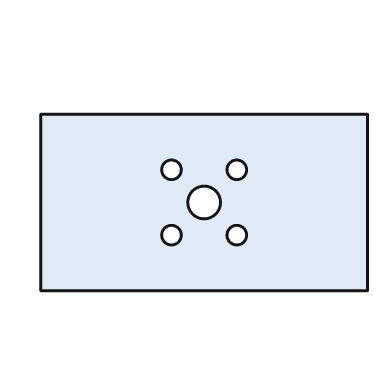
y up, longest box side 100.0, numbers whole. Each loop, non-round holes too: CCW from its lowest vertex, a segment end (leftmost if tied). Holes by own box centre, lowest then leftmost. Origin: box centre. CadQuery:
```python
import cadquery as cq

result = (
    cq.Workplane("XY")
    .moveTo(-50.0, -27.0)
    .lineTo(50.0, -27.0)
    .lineTo(50.0, 27.0)
    .lineTo(-50.0, 27.0)
    .close()
    .moveTo(-10.0, -10.0)
    .circle(3.0)
    .moveTo(10.0, -10.0)
    .circle(3.0)
    .moveTo(0.0, 0.0)
    .circle(5.0)
    .moveTo(-10.0, 10.0)
    .circle(3.0)
    .moveTo(10.0, 10.0)
    .circle(3.0)
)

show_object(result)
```